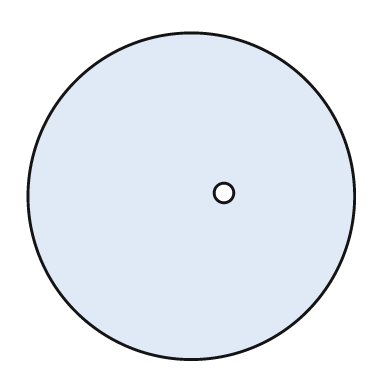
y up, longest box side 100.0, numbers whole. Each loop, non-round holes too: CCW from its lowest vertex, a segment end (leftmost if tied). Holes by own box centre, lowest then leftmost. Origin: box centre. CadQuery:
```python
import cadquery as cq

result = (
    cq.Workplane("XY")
    .moveTo(0.0, 0.0)
    .circle(50.0)
    .moveTo(10.0, 1.0)
    .circle(3.0)
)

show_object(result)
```